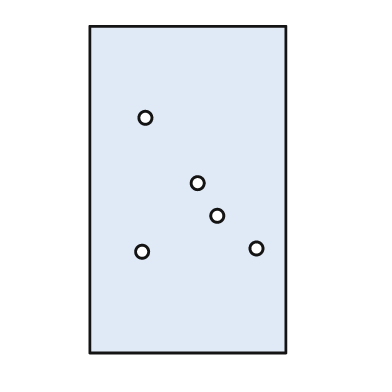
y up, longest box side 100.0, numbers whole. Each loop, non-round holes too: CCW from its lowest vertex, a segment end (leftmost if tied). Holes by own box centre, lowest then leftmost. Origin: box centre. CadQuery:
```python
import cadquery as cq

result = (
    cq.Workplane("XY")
    .moveTo(-30.0, -50.0)
    .lineTo(30.0, -50.0)
    .lineTo(30.0, 50.0)
    .lineTo(-30.0, 50.0)
    .close()
    .moveTo(-14.0, -19.0)
    .circle(2.0)
    .moveTo(21.0, -18.0)
    .circle(2.0)
    .moveTo(9.0, -8.0)
    .circle(2.0)
    .moveTo(3.0, 2.0)
    .circle(2.0)
    .moveTo(-13.0, 22.0)
    .circle(2.0)
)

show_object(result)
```